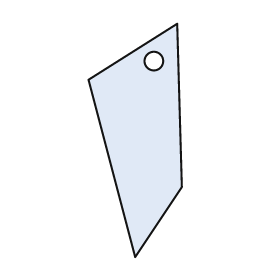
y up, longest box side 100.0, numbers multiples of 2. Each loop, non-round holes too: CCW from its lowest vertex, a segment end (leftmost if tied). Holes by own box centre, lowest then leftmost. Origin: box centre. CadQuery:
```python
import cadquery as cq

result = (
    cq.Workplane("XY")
    .moveTo(0.0, -50.0)
    .lineTo(20.0, -20.0)
    .lineTo(18.0, 50.0)
    .lineTo(-20.0, 26.0)
    .close()
    .moveTo(8.0, 34.0)
    .circle(4.0)
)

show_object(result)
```